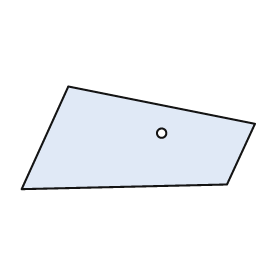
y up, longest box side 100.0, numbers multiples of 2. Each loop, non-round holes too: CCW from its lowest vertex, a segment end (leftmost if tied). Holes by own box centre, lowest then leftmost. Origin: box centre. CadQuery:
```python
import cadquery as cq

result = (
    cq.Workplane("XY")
    .moveTo(-50.0, -22.0)
    .lineTo(38.0, -20.0)
    .lineTo(50.0, 6.0)
    .lineTo(-30.0, 22.0)
    .close()
    .moveTo(10.0, 2.0)
    .circle(2.0)
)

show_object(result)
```